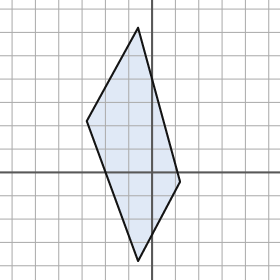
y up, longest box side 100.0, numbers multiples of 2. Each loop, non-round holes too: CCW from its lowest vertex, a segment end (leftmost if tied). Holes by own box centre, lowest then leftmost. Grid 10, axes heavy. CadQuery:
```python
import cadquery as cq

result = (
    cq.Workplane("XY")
    .moveTo(-6.0, -38.0)
    .lineTo(12.0, -4.0)
    .lineTo(-6.0, 62.0)
    .lineTo(-28.0, 22.0)
    .close()
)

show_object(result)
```